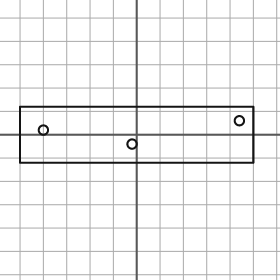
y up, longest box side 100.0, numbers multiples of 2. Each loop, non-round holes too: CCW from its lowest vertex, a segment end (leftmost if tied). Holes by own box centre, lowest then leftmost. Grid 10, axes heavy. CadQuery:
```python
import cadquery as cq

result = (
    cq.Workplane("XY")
    .moveTo(-50.0, -12.0)
    .lineTo(50.0, -12.0)
    .lineTo(50.0, 12.0)
    .lineTo(-50.0, 12.0)
    .close()
    .moveTo(-2.0, -4.0)
    .circle(2.0)
    .moveTo(-40.0, 2.0)
    .circle(2.0)
    .moveTo(44.0, 6.0)
    .circle(2.0)
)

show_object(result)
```